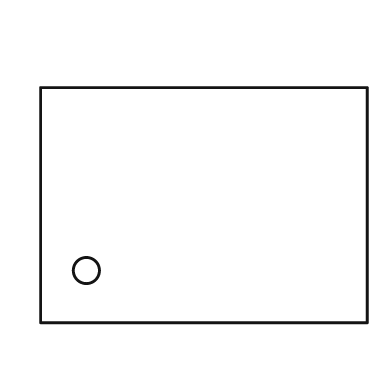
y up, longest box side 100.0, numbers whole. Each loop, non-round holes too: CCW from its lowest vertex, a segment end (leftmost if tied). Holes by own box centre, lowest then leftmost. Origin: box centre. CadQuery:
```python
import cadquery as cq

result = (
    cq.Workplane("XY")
    .moveTo(-50.0, -36.0)
    .lineTo(50.0, -36.0)
    .lineTo(50.0, 36.0)
    .lineTo(-50.0, 36.0)
    .close()
    .moveTo(-36.0, -20.0)
    .circle(4.0)
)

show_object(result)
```